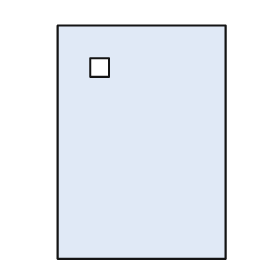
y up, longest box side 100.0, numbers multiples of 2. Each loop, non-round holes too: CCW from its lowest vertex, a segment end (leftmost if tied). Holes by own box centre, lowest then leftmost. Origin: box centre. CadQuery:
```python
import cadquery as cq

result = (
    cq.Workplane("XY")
    .moveTo(-36.0, -50.0)
    .lineTo(36.0, -50.0)
    .lineTo(36.0, 50.0)
    .lineTo(-36.0, 50.0)
    .close()
    .moveTo(-22.0, 28.0)
    .lineTo(-14.0, 28.0)
    .lineTo(-14.0, 36.0)
    .lineTo(-22.0, 36.0)
    .close()
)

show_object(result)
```